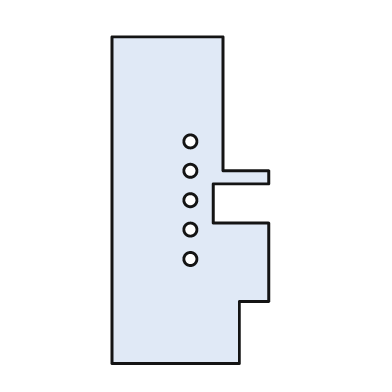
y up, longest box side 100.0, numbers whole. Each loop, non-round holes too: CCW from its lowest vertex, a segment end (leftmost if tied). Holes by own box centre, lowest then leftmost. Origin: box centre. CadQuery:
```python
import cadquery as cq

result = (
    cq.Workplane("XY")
    .moveTo(-24.0, -50.0)
    .lineTo(15.0, -50.0)
    .lineTo(15.0, -31.0)
    .lineTo(24.0, -31.0)
    .lineTo(24.0, -7.0)
    .lineTo(7.0, -7.0)
    .lineTo(7.0, 5.0)
    .lineTo(24.0, 5.0)
    .lineTo(24.0, 9.0)
    .lineTo(10.0, 9.0)
    .lineTo(10.0, 50.0)
    .lineTo(-24.0, 50.0)
    .close()
    .moveTo(0.0, -18.0)
    .circle(2.0)
    .moveTo(0.0, -9.0)
    .circle(2.0)
    .moveTo(0.0, 0.0)
    .circle(2.0)
    .moveTo(0.0, 9.0)
    .circle(2.0)
    .moveTo(0.0, 18.0)
    .circle(2.0)
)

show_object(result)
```